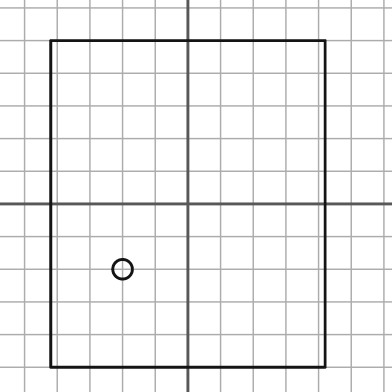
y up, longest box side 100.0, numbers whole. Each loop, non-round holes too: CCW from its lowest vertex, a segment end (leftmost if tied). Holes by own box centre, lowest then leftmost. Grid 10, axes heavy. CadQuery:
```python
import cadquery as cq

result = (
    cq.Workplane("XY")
    .moveTo(-42.0, -50.0)
    .lineTo(42.0, -50.0)
    .lineTo(42.0, 50.0)
    .lineTo(-42.0, 50.0)
    .close()
    .moveTo(-20.0, -20.0)
    .circle(3.0)
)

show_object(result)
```